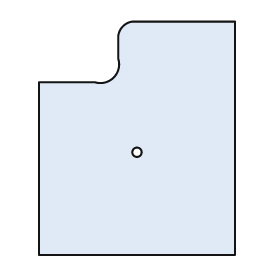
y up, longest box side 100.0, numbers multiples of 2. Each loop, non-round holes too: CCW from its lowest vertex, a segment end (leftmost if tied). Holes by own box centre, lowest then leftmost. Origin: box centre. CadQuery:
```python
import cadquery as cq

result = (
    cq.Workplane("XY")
    .moveTo(-42.0, -50.0)
    .lineTo(42.0, -50.0)
    .lineTo(42.0, 50.0)
    .lineTo(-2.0, 50.0)
    .threePointArc((-6.0, 48.0), (-8.0, 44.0))
    .lineTo(-8.0, 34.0)
    .threePointArc((-10.0, 26.0), (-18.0, 24.0))
    .lineTo(-42.0, 24.0)
    .close()
    .moveTo(0.0, -6.0)
    .circle(2.0)
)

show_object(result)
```